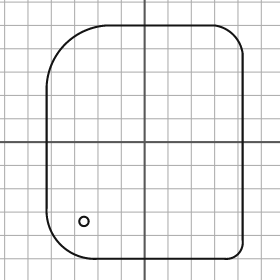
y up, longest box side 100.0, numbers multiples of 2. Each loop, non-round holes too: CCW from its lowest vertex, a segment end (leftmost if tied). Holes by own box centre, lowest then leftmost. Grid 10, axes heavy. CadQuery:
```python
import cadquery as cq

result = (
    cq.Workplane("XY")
    .moveTo(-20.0, -50.0)
    .lineTo(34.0, -50.0)
    .threePointArc((40.0, -48.0), (42.0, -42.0))
    .lineTo(42.0, 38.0)
    .threePointArc((38.0, 46.0), (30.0, 50.0))
    .lineTo(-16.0, 50.0)
    .threePointArc((-34.0, 42.0), (-42.0, 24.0))
    .lineTo(-42.0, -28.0)
    .threePointArc((-36.0, -44.0), (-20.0, -50.0))
    .close()
    .moveTo(-26.0, -34.0)
    .circle(2.0)
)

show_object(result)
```